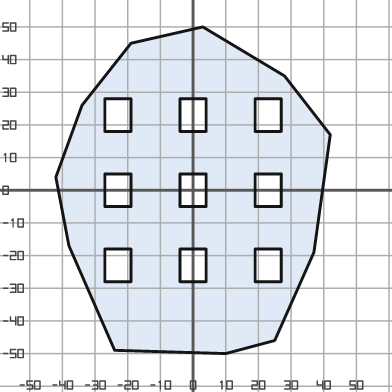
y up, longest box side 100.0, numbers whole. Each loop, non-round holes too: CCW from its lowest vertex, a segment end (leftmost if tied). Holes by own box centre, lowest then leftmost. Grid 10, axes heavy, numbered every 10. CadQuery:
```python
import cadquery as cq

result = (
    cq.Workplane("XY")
    .moveTo(10.0, -50.0)
    .lineTo(25.0, -46.0)
    .lineTo(37.0, -19.0)
    .lineTo(42.0, 17.0)
    .lineTo(28.0, 35.0)
    .lineTo(3.0, 50.0)
    .lineTo(-19.0, 45.0)
    .lineTo(-34.0, 26.0)
    .lineTo(-42.0, 4.0)
    .lineTo(-38.0, -17.0)
    .lineTo(-24.0, -49.0)
    .close()
    .moveTo(-27.0, -28.0)
    .lineTo(-19.0, -28.0)
    .lineTo(-19.0, -18.0)
    .lineTo(-27.0, -18.0)
    .close()
    .moveTo(-4.0, -28.0)
    .lineTo(4.0, -28.0)
    .lineTo(4.0, -18.0)
    .lineTo(-4.0, -18.0)
    .close()
    .moveTo(19.0, -28.0)
    .lineTo(27.0, -28.0)
    .lineTo(27.0, -18.0)
    .lineTo(19.0, -18.0)
    .close()
    .moveTo(-27.0, -5.0)
    .lineTo(-19.0, -5.0)
    .lineTo(-19.0, 5.0)
    .lineTo(-27.0, 5.0)
    .close()
    .moveTo(-4.0, -5.0)
    .lineTo(4.0, -5.0)
    .lineTo(4.0, 5.0)
    .lineTo(-4.0, 5.0)
    .close()
    .moveTo(19.0, -5.0)
    .lineTo(27.0, -5.0)
    .lineTo(27.0, 5.0)
    .lineTo(19.0, 5.0)
    .close()
    .moveTo(-27.0, 18.0)
    .lineTo(-19.0, 18.0)
    .lineTo(-19.0, 28.0)
    .lineTo(-27.0, 28.0)
    .close()
    .moveTo(-4.0, 18.0)
    .lineTo(4.0, 18.0)
    .lineTo(4.0, 28.0)
    .lineTo(-4.0, 28.0)
    .close()
    .moveTo(19.0, 18.0)
    .lineTo(27.0, 18.0)
    .lineTo(27.0, 28.0)
    .lineTo(19.0, 28.0)
    .close()
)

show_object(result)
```